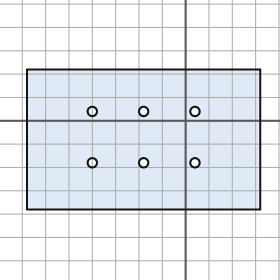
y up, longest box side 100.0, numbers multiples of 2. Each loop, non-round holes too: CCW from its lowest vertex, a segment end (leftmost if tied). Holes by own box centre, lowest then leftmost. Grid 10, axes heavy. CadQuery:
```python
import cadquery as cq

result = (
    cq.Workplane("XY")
    .moveTo(-68.0, -38.0)
    .lineTo(32.0, -38.0)
    .lineTo(32.0, 22.0)
    .lineTo(-68.0, 22.0)
    .close()
    .moveTo(-40.0, -18.0)
    .circle(2.0)
    .moveTo(-18.0, -18.0)
    .circle(2.0)
    .moveTo(4.0, -18.0)
    .circle(2.0)
    .moveTo(-40.0, 4.0)
    .circle(2.0)
    .moveTo(-18.0, 4.0)
    .circle(2.0)
    .moveTo(4.0, 4.0)
    .circle(2.0)
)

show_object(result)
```